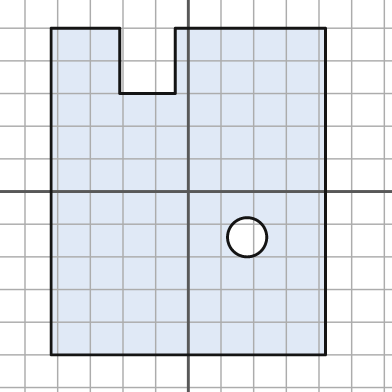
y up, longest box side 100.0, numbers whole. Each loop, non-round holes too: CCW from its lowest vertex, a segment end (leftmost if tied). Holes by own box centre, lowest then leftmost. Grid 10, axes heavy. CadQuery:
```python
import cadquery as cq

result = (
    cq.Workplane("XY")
    .moveTo(-42.0, -50.0)
    .lineTo(42.0, -50.0)
    .lineTo(42.0, 50.0)
    .lineTo(-4.0, 50.0)
    .lineTo(-4.0, 30.0)
    .lineTo(-21.0, 30.0)
    .lineTo(-21.0, 50.0)
    .lineTo(-42.0, 50.0)
    .close()
    .moveTo(18.0, -14.0)
    .circle(6.0)
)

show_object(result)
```